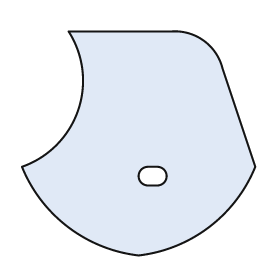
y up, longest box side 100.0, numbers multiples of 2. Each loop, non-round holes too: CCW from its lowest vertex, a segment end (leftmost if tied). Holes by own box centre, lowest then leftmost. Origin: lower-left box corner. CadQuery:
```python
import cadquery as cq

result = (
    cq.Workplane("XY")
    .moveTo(50.0, 0.0)
    .threePointArc((80.0, 12.0), (100.0, 38.0))
    .lineTo(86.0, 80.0)
    .threePointArc((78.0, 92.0), (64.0, 96.0))
    .lineTo(20.0, 96.0)
    .threePointArc((24.0, 62.0), (0.0, 38.0))
    .threePointArc((20.0, 12.0), (50.0, 0.0))
    .close()
    .moveTo(54.0, 30.0)
    .lineTo(58.0, 30.0)
    .threePointArc((62.0, 34.0), (58.0, 38.0))
    .lineTo(54.0, 38.0)
    .threePointArc((50.0, 34.0), (54.0, 30.0))
    .close()
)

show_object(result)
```